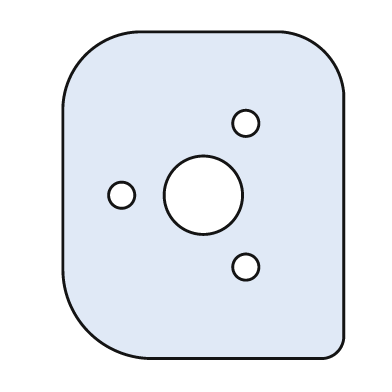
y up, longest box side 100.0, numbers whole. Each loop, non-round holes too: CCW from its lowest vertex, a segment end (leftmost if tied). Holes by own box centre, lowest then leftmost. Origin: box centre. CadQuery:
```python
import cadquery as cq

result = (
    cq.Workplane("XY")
    .moveTo(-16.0, -50.0)
    .lineTo(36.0, -50.0)
    .threePointArc((41.0, -48.0), (43.0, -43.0))
    .lineTo(43.0, 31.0)
    .threePointArc((37.0, 44.0), (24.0, 50.0))
    .lineTo(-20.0, 50.0)
    .threePointArc((-36.0, 43.0), (-43.0, 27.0))
    .lineTo(-43.0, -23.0)
    .threePointArc((-35.0, -42.0), (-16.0, -50.0))
    .close()
    .moveTo(13.0, -22.0)
    .circle(4.0)
    .moveTo(-25.0, 0.0)
    .circle(4.0)
    .moveTo(0.0, 0.0)
    .circle(12.0)
    .moveTo(13.0, 22.0)
    .circle(4.0)
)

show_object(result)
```